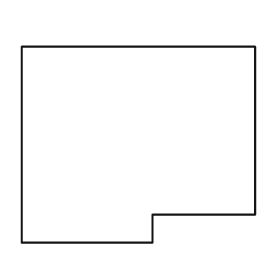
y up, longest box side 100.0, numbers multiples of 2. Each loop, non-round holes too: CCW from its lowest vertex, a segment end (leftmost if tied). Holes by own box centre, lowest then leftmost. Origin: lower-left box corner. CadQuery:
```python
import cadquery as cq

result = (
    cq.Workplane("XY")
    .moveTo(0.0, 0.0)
    .lineTo(56.0, 0.0)
    .lineTo(56.0, 12.0)
    .lineTo(100.0, 12.0)
    .lineTo(100.0, 84.0)
    .lineTo(0.0, 84.0)
    .close()
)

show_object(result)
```